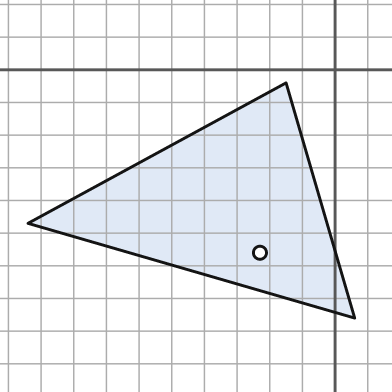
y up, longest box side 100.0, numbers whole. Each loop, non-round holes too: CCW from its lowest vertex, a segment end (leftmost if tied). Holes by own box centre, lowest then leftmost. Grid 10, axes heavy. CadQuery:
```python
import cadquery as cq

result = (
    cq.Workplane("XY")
    .moveTo(6.0, -76.0)
    .lineTo(-15.0, -4.0)
    .lineTo(-94.0, -47.0)
    .close()
    .moveTo(-23.0, -56.0)
    .circle(2.0)
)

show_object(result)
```